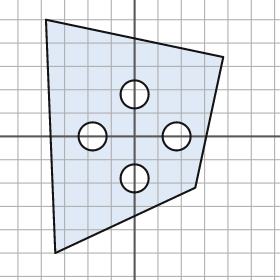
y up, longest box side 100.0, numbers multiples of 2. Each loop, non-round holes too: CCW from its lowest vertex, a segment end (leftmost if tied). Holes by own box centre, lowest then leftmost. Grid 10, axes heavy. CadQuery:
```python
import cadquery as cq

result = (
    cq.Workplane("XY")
    .moveTo(-34.0, -50.0)
    .lineTo(26.0, -22.0)
    .lineTo(38.0, 34.0)
    .lineTo(-38.0, 50.0)
    .close()
    .moveTo(0.0, -18.0)
    .circle(6.0)
    .moveTo(-18.0, 0.0)
    .circle(6.0)
    .moveTo(18.0, 0.0)
    .circle(6.0)
    .moveTo(0.0, 18.0)
    .circle(6.0)
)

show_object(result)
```